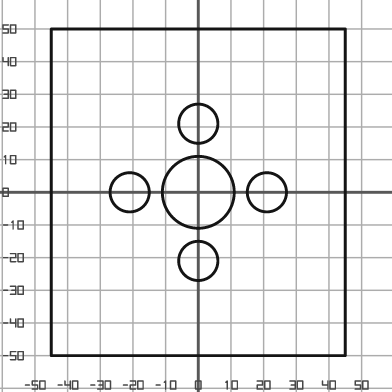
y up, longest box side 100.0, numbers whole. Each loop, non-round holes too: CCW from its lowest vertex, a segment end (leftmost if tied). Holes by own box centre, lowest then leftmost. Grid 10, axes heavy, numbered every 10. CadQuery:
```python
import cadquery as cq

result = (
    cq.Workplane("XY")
    .moveTo(-45.0, -50.0)
    .lineTo(45.0, -50.0)
    .lineTo(45.0, 50.0)
    .lineTo(-45.0, 50.0)
    .close()
    .moveTo(0.0, -21.0)
    .circle(6.0)
    .moveTo(-21.0, 0.0)
    .circle(6.0)
    .moveTo(0.0, 0.0)
    .circle(11.0)
    .moveTo(21.0, 0.0)
    .circle(6.0)
    .moveTo(0.0, 21.0)
    .circle(6.0)
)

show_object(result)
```